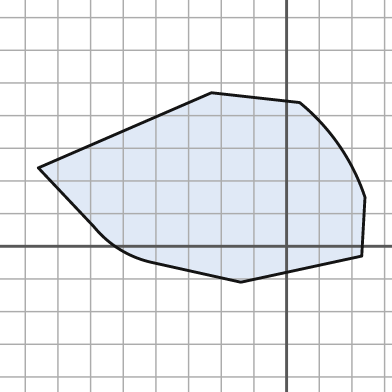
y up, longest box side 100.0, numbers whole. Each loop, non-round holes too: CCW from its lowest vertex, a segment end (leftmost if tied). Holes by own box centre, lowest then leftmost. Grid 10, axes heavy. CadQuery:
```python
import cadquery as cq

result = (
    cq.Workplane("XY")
    .moveTo(-14.0, -11.0)
    .lineTo(23.0, -3.0)
    .lineTo(24.0, 15.0)
    .threePointArc((16.0, 31.0), (4.0, 44.0))
    .lineTo(-23.0, 47.0)
    .lineTo(-76.0, 24.0)
    .lineTo(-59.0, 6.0)
    .threePointArc((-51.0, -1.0), (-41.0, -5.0))
    .close()
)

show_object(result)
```